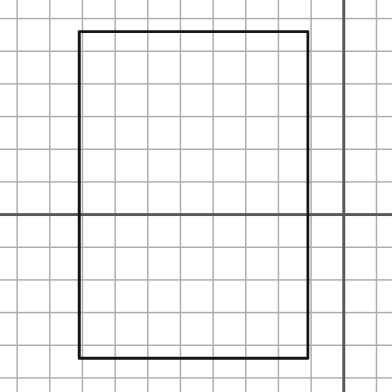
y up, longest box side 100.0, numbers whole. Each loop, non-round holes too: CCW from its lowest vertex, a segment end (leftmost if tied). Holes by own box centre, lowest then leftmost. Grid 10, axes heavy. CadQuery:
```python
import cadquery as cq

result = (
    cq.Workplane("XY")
    .moveTo(-81.0, -44.0)
    .lineTo(-11.0, -44.0)
    .lineTo(-11.0, 56.0)
    .lineTo(-81.0, 56.0)
    .close()
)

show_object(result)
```